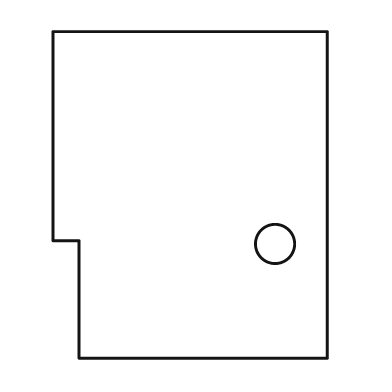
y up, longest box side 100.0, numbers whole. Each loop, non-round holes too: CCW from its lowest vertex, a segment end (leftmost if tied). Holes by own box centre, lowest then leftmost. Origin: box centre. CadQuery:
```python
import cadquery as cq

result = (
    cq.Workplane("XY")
    .moveTo(-34.0, -50.0)
    .lineTo(42.0, -50.0)
    .lineTo(42.0, 50.0)
    .lineTo(-42.0, 50.0)
    .lineTo(-42.0, -14.0)
    .lineTo(-34.0, -14.0)
    .close()
    .moveTo(26.0, -15.0)
    .circle(6.0)
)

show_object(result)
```